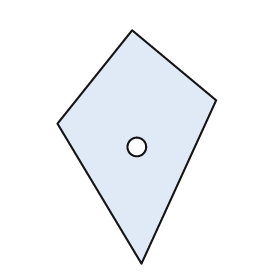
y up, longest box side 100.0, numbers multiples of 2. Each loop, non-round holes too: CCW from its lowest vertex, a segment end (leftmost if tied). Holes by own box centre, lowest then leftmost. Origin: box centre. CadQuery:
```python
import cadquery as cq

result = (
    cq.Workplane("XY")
    .moveTo(2.0, -50.0)
    .lineTo(34.0, 20.0)
    .lineTo(-2.0, 50.0)
    .lineTo(-34.0, 10.0)
    .close()
    .moveTo(0.0, 0.0)
    .circle(4.0)
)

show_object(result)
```